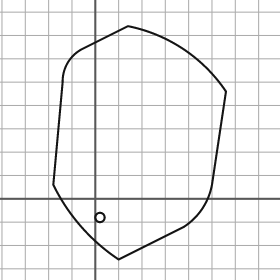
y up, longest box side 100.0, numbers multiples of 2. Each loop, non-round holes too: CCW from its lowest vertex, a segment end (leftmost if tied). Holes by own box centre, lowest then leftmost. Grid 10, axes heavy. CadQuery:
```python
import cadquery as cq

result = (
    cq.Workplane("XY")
    .moveTo(10.0, -26.0)
    .lineTo(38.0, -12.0)
    .threePointArc((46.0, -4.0), (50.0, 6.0))
    .lineTo(56.0, 46.0)
    .threePointArc((38.0, 64.0), (14.0, 74.0))
    .lineTo(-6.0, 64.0)
    .threePointArc((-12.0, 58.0), (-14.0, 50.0))
    .lineTo(-18.0, 6.0)
    .threePointArc((-6.0, -12.0), (10.0, -26.0))
    .close()
    .moveTo(2.0, -8.0)
    .circle(2.0)
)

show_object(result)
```